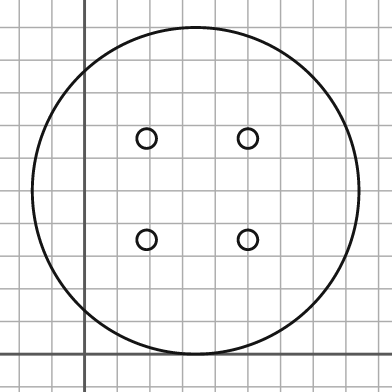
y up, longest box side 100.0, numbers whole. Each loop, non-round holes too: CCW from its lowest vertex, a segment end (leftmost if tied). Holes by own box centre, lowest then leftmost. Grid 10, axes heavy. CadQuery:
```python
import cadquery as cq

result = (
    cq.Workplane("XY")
    .moveTo(34.0, 50.0)
    .circle(50.0)
    .moveTo(19.0, 35.0)
    .circle(3.0)
    .moveTo(50.0, 35.0)
    .circle(3.0)
    .moveTo(19.0, 66.0)
    .circle(3.0)
    .moveTo(50.0, 66.0)
    .circle(3.0)
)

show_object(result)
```